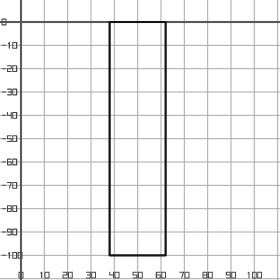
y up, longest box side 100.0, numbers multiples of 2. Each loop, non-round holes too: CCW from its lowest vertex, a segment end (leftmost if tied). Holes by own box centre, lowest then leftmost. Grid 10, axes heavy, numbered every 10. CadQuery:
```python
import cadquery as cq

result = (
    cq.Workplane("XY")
    .moveTo(38.0, -100.0)
    .lineTo(62.0, -100.0)
    .lineTo(62.0, 0.0)
    .lineTo(38.0, 0.0)
    .close()
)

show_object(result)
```